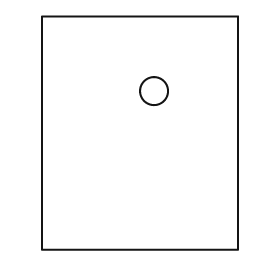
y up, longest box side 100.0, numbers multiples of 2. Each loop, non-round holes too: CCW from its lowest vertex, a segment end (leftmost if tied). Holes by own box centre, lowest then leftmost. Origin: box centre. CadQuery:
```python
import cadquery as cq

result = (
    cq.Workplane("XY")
    .moveTo(-42.0, -50.0)
    .lineTo(42.0, -50.0)
    .lineTo(42.0, 50.0)
    .lineTo(-42.0, 50.0)
    .close()
    .moveTo(6.0, 18.0)
    .circle(6.0)
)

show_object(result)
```